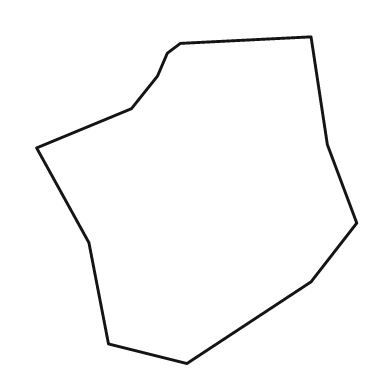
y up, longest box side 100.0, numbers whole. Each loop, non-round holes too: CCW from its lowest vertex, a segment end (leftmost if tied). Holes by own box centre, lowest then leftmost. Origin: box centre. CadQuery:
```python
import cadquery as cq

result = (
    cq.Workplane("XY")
    .moveTo(-3.0, -50.0)
    .lineTo(35.0, -25.0)
    .lineTo(49.0, -7.0)
    .lineTo(40.0, 17.0)
    .lineTo(35.0, 50.0)
    .lineTo(-5.0, 48.0)
    .lineTo(-9.0, 45.0)
    .lineTo(-12.0, 38.0)
    .lineTo(-20.0, 28.0)
    .lineTo(-49.0, 16.0)
    .lineTo(-33.0, -13.0)
    .lineTo(-27.0, -44.0)
    .close()
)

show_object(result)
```